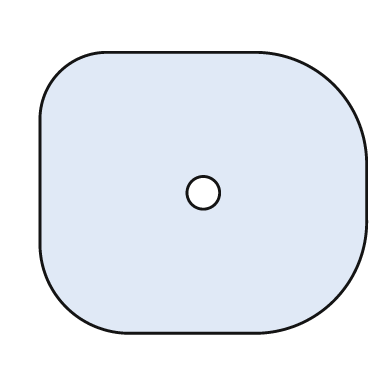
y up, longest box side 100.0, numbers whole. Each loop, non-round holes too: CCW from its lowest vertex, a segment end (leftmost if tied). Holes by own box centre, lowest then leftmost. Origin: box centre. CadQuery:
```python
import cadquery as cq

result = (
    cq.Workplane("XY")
    .moveTo(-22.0, -43.0)
    .lineTo(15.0, -43.0)
    .threePointArc((40.0, -33.0), (50.0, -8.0))
    .lineTo(50.0, 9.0)
    .threePointArc((40.0, 33.0), (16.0, 43.0))
    .lineTo(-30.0, 43.0)
    .threePointArc((-44.0, 37.0), (-50.0, 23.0))
    .lineTo(-50.0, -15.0)
    .threePointArc((-42.0, -35.0), (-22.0, -43.0))
    .close()
    .moveTo(0.0, 0.0)
    .circle(5.0)
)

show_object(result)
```